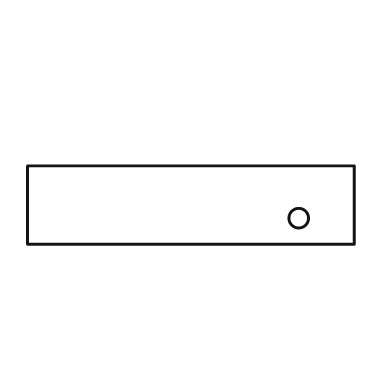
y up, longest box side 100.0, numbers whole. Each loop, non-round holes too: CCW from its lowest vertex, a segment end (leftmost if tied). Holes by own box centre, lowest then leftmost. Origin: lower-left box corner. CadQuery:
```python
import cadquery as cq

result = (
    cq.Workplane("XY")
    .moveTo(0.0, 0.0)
    .lineTo(100.0, 0.0)
    .lineTo(100.0, 24.0)
    .lineTo(0.0, 24.0)
    .close()
    .moveTo(83.0, 8.0)
    .circle(3.0)
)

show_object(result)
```